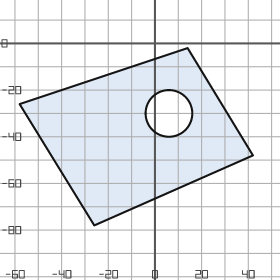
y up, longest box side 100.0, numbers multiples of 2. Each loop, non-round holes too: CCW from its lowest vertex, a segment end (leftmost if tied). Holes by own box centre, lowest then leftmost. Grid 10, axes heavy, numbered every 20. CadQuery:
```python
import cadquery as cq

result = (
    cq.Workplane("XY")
    .moveTo(-26.0, -78.0)
    .lineTo(42.0, -48.0)
    .lineTo(14.0, -2.0)
    .lineTo(-58.0, -26.0)
    .close()
    .moveTo(6.0, -30.0)
    .circle(10.0)
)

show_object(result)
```